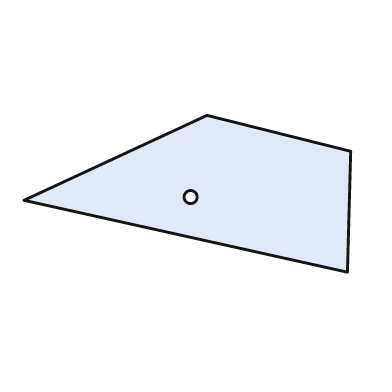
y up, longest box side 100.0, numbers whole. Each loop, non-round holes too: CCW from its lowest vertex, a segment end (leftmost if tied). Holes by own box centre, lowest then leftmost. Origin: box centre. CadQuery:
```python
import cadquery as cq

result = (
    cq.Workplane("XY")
    .moveTo(49.0, -24.0)
    .lineTo(50.0, 13.0)
    .lineTo(6.0, 24.0)
    .lineTo(-50.0, -2.0)
    .close()
    .moveTo(1.0, -1.0)
    .circle(2.0)
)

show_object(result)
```